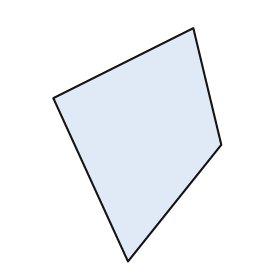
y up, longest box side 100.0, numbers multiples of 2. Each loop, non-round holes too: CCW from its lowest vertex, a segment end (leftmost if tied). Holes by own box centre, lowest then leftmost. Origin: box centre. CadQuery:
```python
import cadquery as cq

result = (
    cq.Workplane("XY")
    .moveTo(-4.0, -50.0)
    .lineTo(36.0, 0.0)
    .lineTo(24.0, 50.0)
    .lineTo(-36.0, 20.0)
    .close()
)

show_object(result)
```